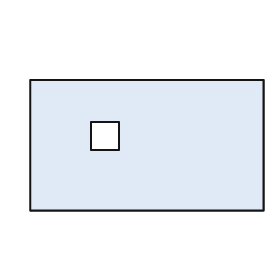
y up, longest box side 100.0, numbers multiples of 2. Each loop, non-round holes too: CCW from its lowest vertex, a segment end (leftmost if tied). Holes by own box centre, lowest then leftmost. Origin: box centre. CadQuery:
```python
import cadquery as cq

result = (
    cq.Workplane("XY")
    .moveTo(-50.0, -28.0)
    .lineTo(50.0, -28.0)
    .lineTo(50.0, 28.0)
    .lineTo(-50.0, 28.0)
    .close()
    .moveTo(-24.0, -2.0)
    .lineTo(-12.0, -2.0)
    .lineTo(-12.0, 10.0)
    .lineTo(-24.0, 10.0)
    .close()
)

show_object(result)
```